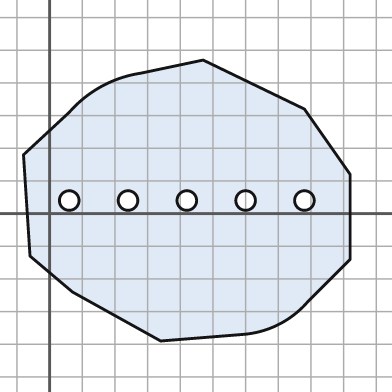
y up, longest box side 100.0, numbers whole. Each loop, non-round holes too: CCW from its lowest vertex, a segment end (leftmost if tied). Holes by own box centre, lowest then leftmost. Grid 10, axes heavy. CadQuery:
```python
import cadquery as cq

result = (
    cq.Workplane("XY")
    .moveTo(34.0, -39.0)
    .lineTo(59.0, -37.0)
    .threePointArc((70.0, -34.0), (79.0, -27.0))
    .lineTo(92.0, -14.0)
    .lineTo(92.0, 12.0)
    .lineTo(78.0, 32.0)
    .lineTo(47.0, 47.0)
    .lineTo(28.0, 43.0)
    .threePointArc((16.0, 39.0), (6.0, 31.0))
    .lineTo(-8.0, 18.0)
    .lineTo(-6.0, -13.0)
    .lineTo(7.0, -24.0)
    .close()
    .moveTo(6.0, 4.0)
    .circle(3.0)
    .moveTo(24.0, 4.0)
    .circle(3.0)
    .moveTo(42.0, 4.0)
    .circle(3.0)
    .moveTo(60.0, 4.0)
    .circle(3.0)
    .moveTo(78.0, 4.0)
    .circle(3.0)
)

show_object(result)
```